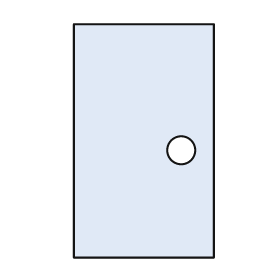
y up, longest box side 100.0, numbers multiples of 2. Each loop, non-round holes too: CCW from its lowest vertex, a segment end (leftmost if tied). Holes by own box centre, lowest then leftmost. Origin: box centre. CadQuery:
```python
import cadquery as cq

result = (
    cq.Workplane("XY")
    .moveTo(-30.0, -50.0)
    .lineTo(30.0, -50.0)
    .lineTo(30.0, 50.0)
    .lineTo(-30.0, 50.0)
    .close()
    .moveTo(16.0, -4.0)
    .circle(6.0)
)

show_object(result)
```